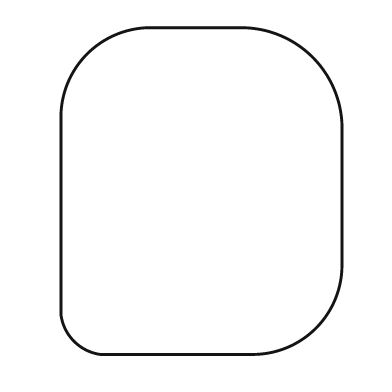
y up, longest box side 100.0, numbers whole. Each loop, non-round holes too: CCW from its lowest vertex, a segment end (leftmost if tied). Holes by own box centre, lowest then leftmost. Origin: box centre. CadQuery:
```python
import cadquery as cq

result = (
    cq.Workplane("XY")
    .moveTo(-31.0, -50.0)
    .lineTo(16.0, -50.0)
    .threePointArc((35.0, -42.0), (43.0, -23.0))
    .lineTo(43.0, 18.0)
    .threePointArc((34.0, 41.0), (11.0, 50.0))
    .lineTo(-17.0, 50.0)
    .threePointArc((-35.0, 42.0), (-43.0, 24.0))
    .lineTo(-43.0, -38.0)
    .threePointArc((-39.0, -46.0), (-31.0, -50.0))
    .close()
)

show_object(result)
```